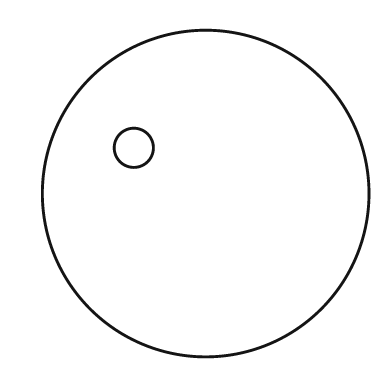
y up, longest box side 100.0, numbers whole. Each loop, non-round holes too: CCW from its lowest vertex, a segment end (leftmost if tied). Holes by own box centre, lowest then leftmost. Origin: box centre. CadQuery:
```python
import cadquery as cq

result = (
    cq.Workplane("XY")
    .moveTo(0.0, 0.0)
    .circle(50.0)
    .moveTo(-22.0, 14.0)
    .circle(6.0)
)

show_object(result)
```